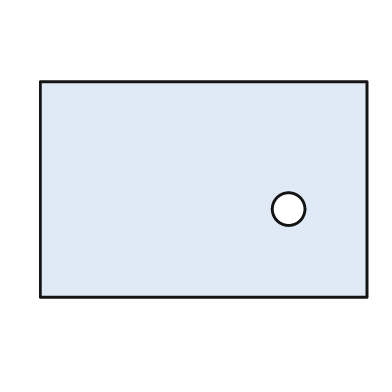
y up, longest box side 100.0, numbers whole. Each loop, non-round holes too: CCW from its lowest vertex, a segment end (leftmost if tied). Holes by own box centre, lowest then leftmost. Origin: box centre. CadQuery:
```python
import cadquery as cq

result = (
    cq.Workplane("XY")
    .moveTo(-50.0, -33.0)
    .lineTo(50.0, -33.0)
    .lineTo(50.0, 33.0)
    .lineTo(-50.0, 33.0)
    .close()
    .moveTo(26.0, -6.0)
    .circle(5.0)
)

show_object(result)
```